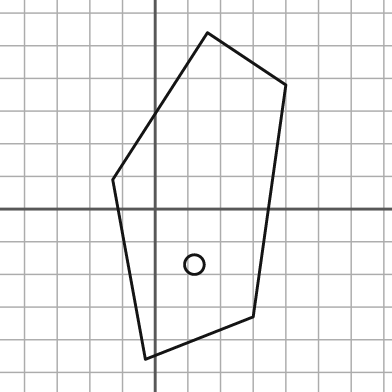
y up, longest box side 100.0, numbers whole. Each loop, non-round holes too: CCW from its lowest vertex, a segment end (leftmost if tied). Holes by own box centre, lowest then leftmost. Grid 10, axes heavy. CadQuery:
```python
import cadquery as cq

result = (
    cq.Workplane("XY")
    .moveTo(-3.0, -46.0)
    .lineTo(30.0, -33.0)
    .lineTo(40.0, 38.0)
    .lineTo(16.0, 54.0)
    .lineTo(-13.0, 9.0)
    .close()
    .moveTo(12.0, -17.0)
    .circle(3.0)
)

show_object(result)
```